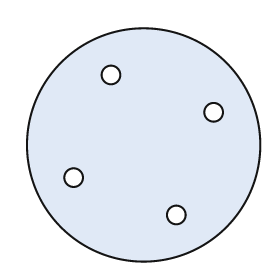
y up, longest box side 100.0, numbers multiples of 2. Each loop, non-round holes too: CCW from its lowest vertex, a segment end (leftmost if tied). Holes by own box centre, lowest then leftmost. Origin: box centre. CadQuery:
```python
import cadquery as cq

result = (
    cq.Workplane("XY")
    .moveTo(0.0, 0.0)
    .circle(50.0)
    .moveTo(14.0, -30.0)
    .circle(4.0)
    .moveTo(-30.0, -14.0)
    .circle(4.0)
    .moveTo(30.0, 14.0)
    .circle(4.0)
    .moveTo(-14.0, 30.0)
    .circle(4.0)
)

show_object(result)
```